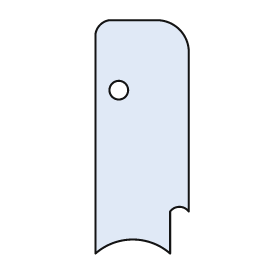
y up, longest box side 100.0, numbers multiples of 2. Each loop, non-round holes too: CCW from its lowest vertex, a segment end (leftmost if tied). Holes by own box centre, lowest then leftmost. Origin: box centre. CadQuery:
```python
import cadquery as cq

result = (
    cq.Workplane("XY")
    .moveTo(-20.0, -50.0)
    .threePointArc((-4.0, -44.0), (12.0, -50.0))
    .lineTo(12.0, -32.0)
    .threePointArc((16.0, -30.0), (20.0, -32.0))
    .lineTo(20.0, 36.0)
    .threePointArc((16.0, 46.0), (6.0, 50.0))
    .lineTo(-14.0, 50.0)
    .threePointArc((-18.0, 48.0), (-20.0, 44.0))
    .close()
    .moveTo(-10.0, 20.0)
    .circle(4.0)
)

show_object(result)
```